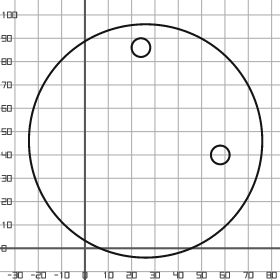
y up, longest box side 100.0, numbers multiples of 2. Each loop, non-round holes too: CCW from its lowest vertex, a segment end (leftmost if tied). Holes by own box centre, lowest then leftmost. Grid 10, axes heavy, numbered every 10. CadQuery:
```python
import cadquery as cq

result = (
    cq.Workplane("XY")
    .moveTo(26.0, 46.0)
    .circle(50.0)
    .moveTo(58.0, 40.0)
    .circle(4.0)
    .moveTo(24.0, 86.0)
    .circle(4.0)
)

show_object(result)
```